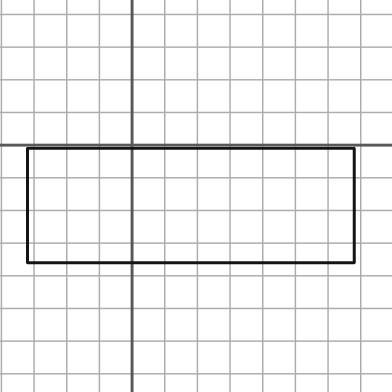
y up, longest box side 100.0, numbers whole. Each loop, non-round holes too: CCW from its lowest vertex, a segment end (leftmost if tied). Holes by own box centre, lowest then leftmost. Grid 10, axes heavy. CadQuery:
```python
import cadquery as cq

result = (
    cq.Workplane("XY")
    .moveTo(-32.0, -36.0)
    .lineTo(68.0, -36.0)
    .lineTo(68.0, -1.0)
    .lineTo(-32.0, -1.0)
    .close()
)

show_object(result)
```